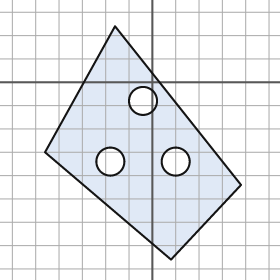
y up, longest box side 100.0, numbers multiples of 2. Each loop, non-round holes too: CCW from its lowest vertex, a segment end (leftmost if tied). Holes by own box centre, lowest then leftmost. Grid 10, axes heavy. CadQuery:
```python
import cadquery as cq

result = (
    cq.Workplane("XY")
    .moveTo(8.0, -76.0)
    .lineTo(38.0, -44.0)
    .lineTo(-16.0, 24.0)
    .lineTo(-46.0, -30.0)
    .close()
    .moveTo(-18.0, -34.0)
    .circle(6.0)
    .moveTo(10.0, -34.0)
    .circle(6.0)
    .moveTo(-4.0, -8.0)
    .circle(6.0)
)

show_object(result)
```